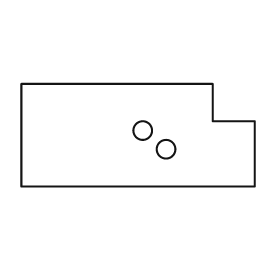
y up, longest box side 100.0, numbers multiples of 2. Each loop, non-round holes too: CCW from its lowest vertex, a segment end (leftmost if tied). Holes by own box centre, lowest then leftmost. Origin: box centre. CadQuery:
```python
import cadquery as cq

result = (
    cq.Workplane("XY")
    .moveTo(-50.0, -22.0)
    .lineTo(50.0, -22.0)
    .lineTo(50.0, 6.0)
    .lineTo(32.0, 6.0)
    .lineTo(32.0, 22.0)
    .lineTo(-50.0, 22.0)
    .close()
    .moveTo(12.0, -6.0)
    .circle(4.0)
    .moveTo(2.0, 2.0)
    .circle(4.0)
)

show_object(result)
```